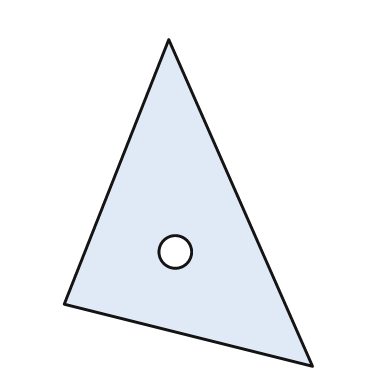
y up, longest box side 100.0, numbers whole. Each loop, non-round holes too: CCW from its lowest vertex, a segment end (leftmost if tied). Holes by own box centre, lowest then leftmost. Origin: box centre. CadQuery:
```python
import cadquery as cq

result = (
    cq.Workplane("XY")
    .moveTo(38.0, -50.0)
    .lineTo(-6.0, 50.0)
    .lineTo(-38.0, -31.0)
    .close()
    .moveTo(-4.0, -15.0)
    .circle(5.0)
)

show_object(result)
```